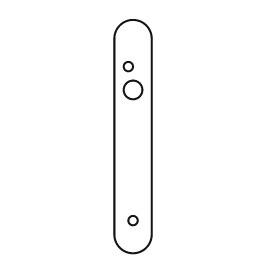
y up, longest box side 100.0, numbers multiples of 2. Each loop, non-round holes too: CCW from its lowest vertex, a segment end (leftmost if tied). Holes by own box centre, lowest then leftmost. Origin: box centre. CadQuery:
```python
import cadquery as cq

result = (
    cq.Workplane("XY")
    .moveTo(-8.0, -42.0)
    .threePointArc((0.0, -50.0), (8.0, -42.0))
    .lineTo(8.0, 42.0)
    .threePointArc((0.0, 50.0), (-8.0, 42.0))
    .close()
    .moveTo(0.0, -36.0)
    .circle(2.0)
    .moveTo(0.0, 20.0)
    .circle(4.0)
    .moveTo(-2.0, 30.0)
    .circle(2.0)
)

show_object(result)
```